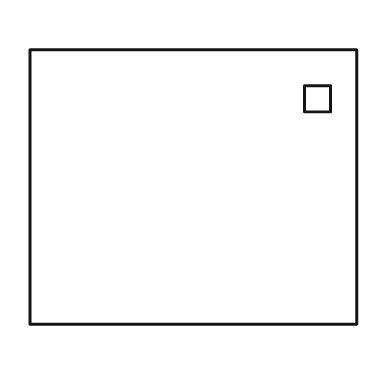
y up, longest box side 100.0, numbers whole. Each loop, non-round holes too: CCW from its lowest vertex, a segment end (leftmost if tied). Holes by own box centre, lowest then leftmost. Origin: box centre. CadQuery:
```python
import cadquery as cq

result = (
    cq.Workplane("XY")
    .moveTo(-50.0, -42.0)
    .lineTo(50.0, -42.0)
    .lineTo(50.0, 42.0)
    .lineTo(-50.0, 42.0)
    .close()
    .moveTo(34.0, 23.0)
    .lineTo(42.0, 23.0)
    .lineTo(42.0, 31.0)
    .lineTo(34.0, 31.0)
    .close()
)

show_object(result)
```